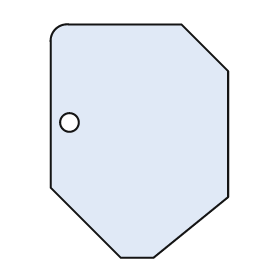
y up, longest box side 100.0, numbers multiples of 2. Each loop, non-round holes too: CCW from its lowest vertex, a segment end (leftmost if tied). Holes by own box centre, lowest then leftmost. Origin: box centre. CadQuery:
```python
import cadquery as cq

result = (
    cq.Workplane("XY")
    .moveTo(-8.0, -50.0)
    .lineTo(6.0, -50.0)
    .lineTo(38.0, -24.0)
    .lineTo(38.0, 30.0)
    .lineTo(18.0, 50.0)
    .lineTo(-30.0, 50.0)
    .threePointArc((-36.0, 48.0), (-38.0, 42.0))
    .lineTo(-38.0, -20.0)
    .close()
    .moveTo(-30.0, 8.0)
    .circle(4.0)
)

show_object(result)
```